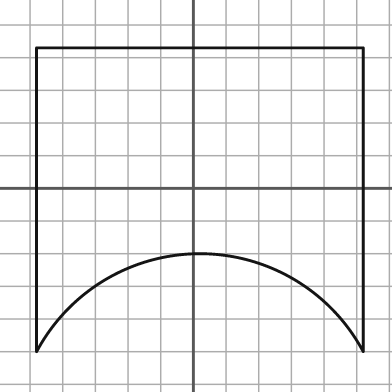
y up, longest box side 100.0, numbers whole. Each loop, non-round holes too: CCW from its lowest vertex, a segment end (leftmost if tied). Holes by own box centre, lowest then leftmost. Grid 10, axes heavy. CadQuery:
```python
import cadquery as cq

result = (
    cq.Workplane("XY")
    .moveTo(-48.0, -50.0)
    .threePointArc((2.0, -20.0), (52.0, -50.0))
    .lineTo(52.0, 43.0)
    .lineTo(-48.0, 43.0)
    .close()
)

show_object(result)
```